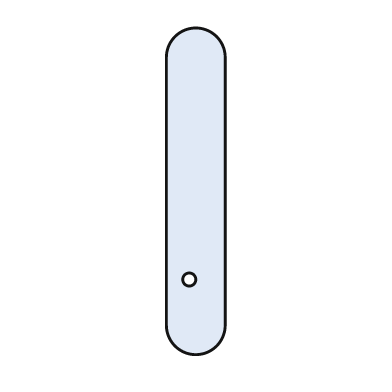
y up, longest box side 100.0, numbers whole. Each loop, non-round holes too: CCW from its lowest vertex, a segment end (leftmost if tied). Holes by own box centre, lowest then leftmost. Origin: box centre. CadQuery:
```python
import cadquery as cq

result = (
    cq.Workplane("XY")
    .moveTo(-9.0, -41.0)
    .threePointArc((0.0, -50.0), (9.0, -41.0))
    .lineTo(9.0, 41.0)
    .threePointArc((0.0, 50.0), (-9.0, 41.0))
    .close()
    .moveTo(-2.0, -27.0)
    .circle(2.0)
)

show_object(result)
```